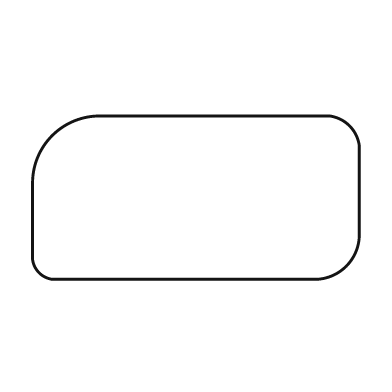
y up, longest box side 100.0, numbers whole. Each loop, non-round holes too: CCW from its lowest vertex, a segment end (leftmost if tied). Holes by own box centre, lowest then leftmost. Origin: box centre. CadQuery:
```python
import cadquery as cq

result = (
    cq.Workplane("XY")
    .moveTo(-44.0, -25.0)
    .lineTo(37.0, -25.0)
    .threePointArc((46.0, -21.0), (50.0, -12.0))
    .lineTo(50.0, 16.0)
    .threePointArc((47.0, 22.0), (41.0, 25.0))
    .lineTo(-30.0, 25.0)
    .threePointArc((-44.0, 19.0), (-50.0, 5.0))
    .lineTo(-50.0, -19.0)
    .threePointArc((-48.0, -23.0), (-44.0, -25.0))
    .close()
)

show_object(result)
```